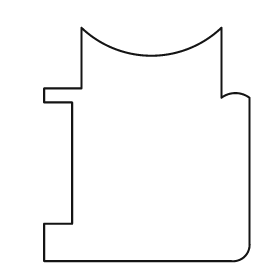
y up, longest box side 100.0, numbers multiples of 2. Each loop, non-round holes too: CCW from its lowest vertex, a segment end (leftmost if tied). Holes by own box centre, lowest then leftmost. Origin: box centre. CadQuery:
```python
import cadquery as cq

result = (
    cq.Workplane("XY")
    .moveTo(-44.0, -50.0)
    .lineTo(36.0, -50.0)
    .threePointArc((42.0, -48.0), (44.0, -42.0))
    .lineTo(44.0, 20.0)
    .threePointArc((38.0, 22.0), (32.0, 20.0))
    .lineTo(32.0, 50.0)
    .threePointArc((2.0, 38.0), (-28.0, 50.0))
    .lineTo(-28.0, 24.0)
    .lineTo(-44.0, 24.0)
    .lineTo(-44.0, 18.0)
    .lineTo(-32.0, 18.0)
    .lineTo(-32.0, -34.0)
    .lineTo(-44.0, -34.0)
    .close()
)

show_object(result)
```